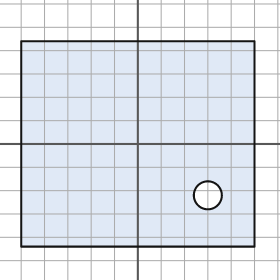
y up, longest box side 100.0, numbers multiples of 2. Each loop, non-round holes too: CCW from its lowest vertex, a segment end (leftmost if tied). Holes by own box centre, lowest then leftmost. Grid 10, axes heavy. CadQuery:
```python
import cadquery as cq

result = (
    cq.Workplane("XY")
    .moveTo(-50.0, -44.0)
    .lineTo(50.0, -44.0)
    .lineTo(50.0, 44.0)
    .lineTo(-50.0, 44.0)
    .close()
    .moveTo(30.0, -22.0)
    .circle(6.0)
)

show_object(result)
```